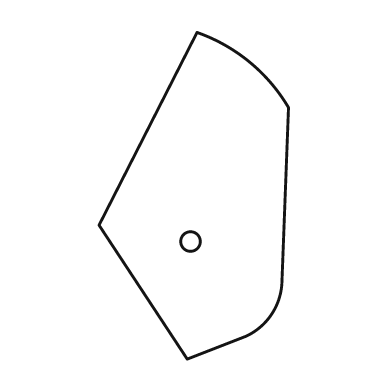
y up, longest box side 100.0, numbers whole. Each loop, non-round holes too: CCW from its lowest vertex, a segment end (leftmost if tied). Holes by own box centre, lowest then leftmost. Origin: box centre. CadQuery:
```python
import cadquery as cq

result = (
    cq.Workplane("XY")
    .moveTo(-2.0, -50.0)
    .lineTo(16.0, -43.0)
    .threePointArc((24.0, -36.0), (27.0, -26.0))
    .lineTo(29.0, 27.0)
    .threePointArc((17.0, 41.0), (1.0, 50.0))
    .lineTo(-29.0, -9.0)
    .close()
    .moveTo(-1.0, -14.0)
    .circle(3.0)
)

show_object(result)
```